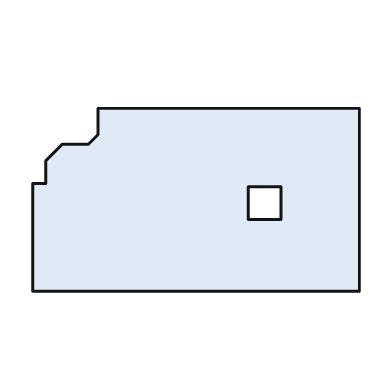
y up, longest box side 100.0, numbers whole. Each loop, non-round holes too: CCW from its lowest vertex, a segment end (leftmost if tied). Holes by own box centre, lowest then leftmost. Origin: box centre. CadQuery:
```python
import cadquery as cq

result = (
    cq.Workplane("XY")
    .moveTo(-50.0, -28.0)
    .lineTo(50.0, -28.0)
    .lineTo(50.0, 28.0)
    .lineTo(-30.0, 28.0)
    .lineTo(-30.0, 20.0)
    .lineTo(-33.0, 17.0)
    .lineTo(-41.0, 17.0)
    .lineTo(-46.0, 12.0)
    .lineTo(-46.0, 5.0)
    .lineTo(-50.0, 5.0)
    .close()
    .moveTo(16.0, -6.0)
    .lineTo(26.0, -6.0)
    .lineTo(26.0, 4.0)
    .lineTo(16.0, 4.0)
    .close()
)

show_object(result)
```